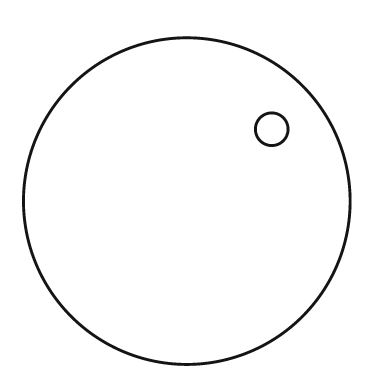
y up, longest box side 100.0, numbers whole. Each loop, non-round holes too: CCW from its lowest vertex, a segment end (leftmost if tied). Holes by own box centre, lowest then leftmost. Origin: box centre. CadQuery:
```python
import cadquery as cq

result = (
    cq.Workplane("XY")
    .moveTo(0.0, 0.0)
    .circle(50.0)
    .moveTo(26.0, 22.0)
    .circle(5.0)
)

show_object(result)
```